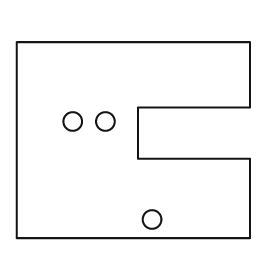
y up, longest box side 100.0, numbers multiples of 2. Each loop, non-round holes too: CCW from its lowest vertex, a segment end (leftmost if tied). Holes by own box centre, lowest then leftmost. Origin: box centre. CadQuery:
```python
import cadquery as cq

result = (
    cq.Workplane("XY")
    .moveTo(-50.0, -42.0)
    .lineTo(50.0, -42.0)
    .lineTo(50.0, -8.0)
    .lineTo(2.0, -8.0)
    .lineTo(2.0, 14.0)
    .lineTo(50.0, 14.0)
    .lineTo(50.0, 42.0)
    .lineTo(-50.0, 42.0)
    .close()
    .moveTo(8.0, -34.0)
    .circle(4.0)
    .moveTo(-26.0, 8.0)
    .circle(4.0)
    .moveTo(-12.0, 8.0)
    .circle(4.0)
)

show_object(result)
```